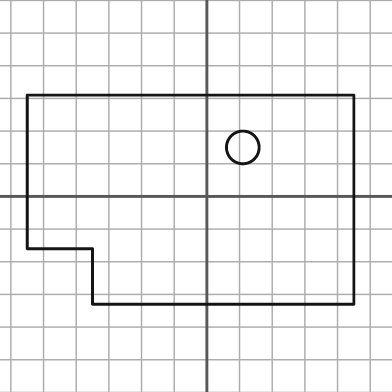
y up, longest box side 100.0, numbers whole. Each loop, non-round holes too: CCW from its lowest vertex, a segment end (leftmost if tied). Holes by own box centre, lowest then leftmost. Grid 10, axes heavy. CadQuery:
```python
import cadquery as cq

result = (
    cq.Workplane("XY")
    .moveTo(-35.0, -33.0)
    .lineTo(45.0, -33.0)
    .lineTo(45.0, 31.0)
    .lineTo(-55.0, 31.0)
    .lineTo(-55.0, -16.0)
    .lineTo(-35.0, -16.0)
    .close()
    .moveTo(11.0, 15.0)
    .circle(5.0)
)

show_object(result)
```